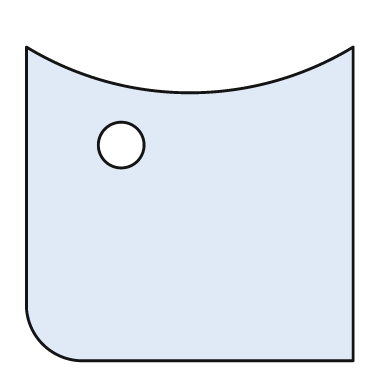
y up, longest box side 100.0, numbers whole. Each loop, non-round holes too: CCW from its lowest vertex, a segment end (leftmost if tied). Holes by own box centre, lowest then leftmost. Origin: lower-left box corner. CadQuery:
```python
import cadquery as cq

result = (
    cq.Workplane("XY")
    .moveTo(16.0, 0.0)
    .lineTo(100.0, 0.0)
    .lineTo(100.0, 96.0)
    .threePointArc((50.0, 82.0), (0.0, 96.0))
    .lineTo(0.0, 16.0)
    .threePointArc((5.0, 5.0), (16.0, 0.0))
    .close()
    .moveTo(29.0, 66.0)
    .circle(7.0)
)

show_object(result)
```